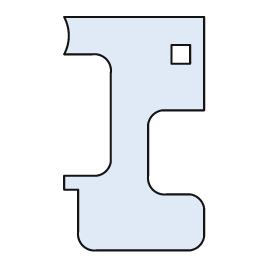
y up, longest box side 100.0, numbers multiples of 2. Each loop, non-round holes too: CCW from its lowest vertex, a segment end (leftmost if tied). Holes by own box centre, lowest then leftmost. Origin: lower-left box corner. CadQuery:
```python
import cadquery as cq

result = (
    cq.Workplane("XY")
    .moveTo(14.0, 0.0)
    .lineTo(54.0, 0.0)
    .threePointArc((58.0, 2.0), (60.0, 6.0))
    .lineTo(60.0, 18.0)
    .threePointArc((58.0, 22.0), (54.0, 24.0))
    .lineTo(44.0, 24.0)
    .threePointArc((38.0, 26.0), (36.0, 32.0))
    .lineTo(36.0, 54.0)
    .threePointArc((38.0, 58.0), (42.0, 60.0))
    .lineTo(60.0, 60.0)
    .lineTo(60.0, 100.0)
    .lineTo(0.0, 100.0)
    .threePointArc((2.0, 92.0), (0.0, 84.0))
    .lineTo(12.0, 84.0)
    .threePointArc((18.0, 82.0), (20.0, 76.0))
    .lineTo(20.0, 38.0)
    .threePointArc((18.0, 34.0), (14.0, 32.0))
    .lineTo(0.0, 32.0)
    .lineTo(0.0, 26.0)
    .lineTo(6.0, 26.0)
    .lineTo(6.0, 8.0)
    .threePointArc((8.0, 2.0), (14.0, 0.0))
    .close()
    .moveTo(46.0, 80.0)
    .lineTo(54.0, 80.0)
    .lineTo(54.0, 88.0)
    .lineTo(46.0, 88.0)
    .close()
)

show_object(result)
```